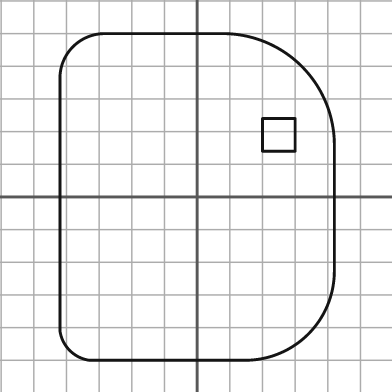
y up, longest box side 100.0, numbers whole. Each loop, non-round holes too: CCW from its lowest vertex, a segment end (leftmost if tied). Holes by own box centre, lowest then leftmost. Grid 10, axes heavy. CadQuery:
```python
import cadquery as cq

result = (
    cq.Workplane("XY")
    .moveTo(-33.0, -50.0)
    .lineTo(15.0, -50.0)
    .threePointArc((34.0, -42.0), (42.0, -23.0))
    .lineTo(42.0, 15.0)
    .threePointArc((32.0, 40.0), (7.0, 50.0))
    .lineTo(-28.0, 50.0)
    .threePointArc((-38.0, 46.0), (-42.0, 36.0))
    .lineTo(-42.0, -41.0)
    .threePointArc((-39.0, -47.0), (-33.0, -50.0))
    .close()
    .moveTo(20.0, 14.0)
    .lineTo(30.0, 14.0)
    .lineTo(30.0, 24.0)
    .lineTo(20.0, 24.0)
    .close()
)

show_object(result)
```